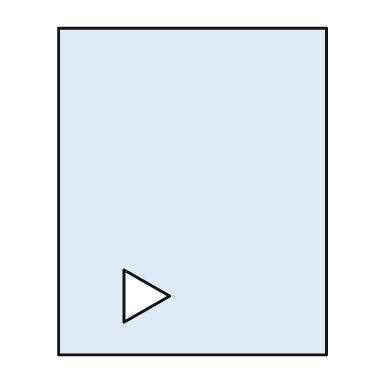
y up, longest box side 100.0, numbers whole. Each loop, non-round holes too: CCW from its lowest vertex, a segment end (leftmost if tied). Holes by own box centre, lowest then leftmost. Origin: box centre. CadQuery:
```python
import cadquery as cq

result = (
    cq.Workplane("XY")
    .moveTo(-41.0, -50.0)
    .lineTo(41.0, -50.0)
    .lineTo(41.0, 50.0)
    .lineTo(-41.0, 50.0)
    .close()
    .moveTo(-21.0, -40.0)
    .lineTo(-7.0, -32.0)
    .lineTo(-21.0, -24.0)
    .close()
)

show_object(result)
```